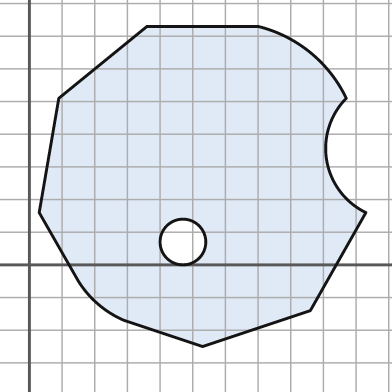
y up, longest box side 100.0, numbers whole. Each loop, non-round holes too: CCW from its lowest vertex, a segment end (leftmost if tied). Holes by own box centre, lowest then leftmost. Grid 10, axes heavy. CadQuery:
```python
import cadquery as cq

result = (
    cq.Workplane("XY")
    .moveTo(53.0, -25.0)
    .lineTo(86.0, -14.0)
    .lineTo(103.0, 16.0)
    .threePointArc((91.0, 32.0), (97.0, 51.0))
    .threePointArc((86.0, 65.0), (70.0, 73.0))
    .lineTo(36.0, 73.0)
    .lineTo(9.0, 51.0)
    .lineTo(3.0, 16.0)
    .lineTo(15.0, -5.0)
    .threePointArc((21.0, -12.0), (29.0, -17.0))
    .close()
    .moveTo(47.0, 7.0)
    .circle(7.0)
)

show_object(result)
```